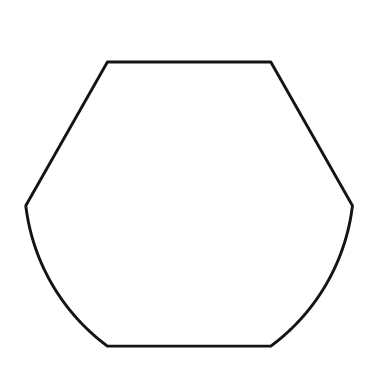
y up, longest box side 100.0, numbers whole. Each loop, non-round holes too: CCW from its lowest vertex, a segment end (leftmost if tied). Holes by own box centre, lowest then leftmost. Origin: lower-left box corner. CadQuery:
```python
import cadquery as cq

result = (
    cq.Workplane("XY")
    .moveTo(25.0, 0.0)
    .lineTo(75.0, 0.0)
    .threePointArc((92.0, 19.0), (100.0, 43.0))
    .lineTo(75.0, 87.0)
    .lineTo(25.0, 87.0)
    .lineTo(0.0, 43.0)
    .threePointArc((8.0, 19.0), (25.0, 0.0))
    .close()
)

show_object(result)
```